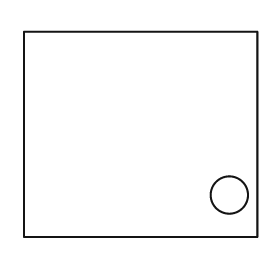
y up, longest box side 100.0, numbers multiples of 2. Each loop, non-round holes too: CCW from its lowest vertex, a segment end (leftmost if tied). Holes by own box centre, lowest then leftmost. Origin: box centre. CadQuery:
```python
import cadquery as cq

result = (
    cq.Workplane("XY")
    .moveTo(-50.0, -44.0)
    .lineTo(50.0, -44.0)
    .lineTo(50.0, 44.0)
    .lineTo(-50.0, 44.0)
    .close()
    .moveTo(38.0, -26.0)
    .circle(8.0)
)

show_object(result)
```